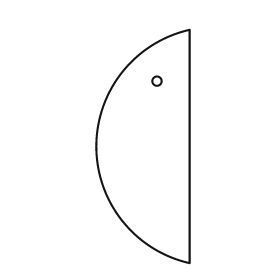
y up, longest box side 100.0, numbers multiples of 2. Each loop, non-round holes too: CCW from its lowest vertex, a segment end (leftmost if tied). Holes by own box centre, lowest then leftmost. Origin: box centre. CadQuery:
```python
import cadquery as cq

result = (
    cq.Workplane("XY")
    .moveTo(20.0, -50.0)
    .lineTo(20.0, 50.0)
    .threePointArc((-20.0, 0.0), (20.0, -50.0))
    .close()
    .moveTo(6.0, 28.0)
    .circle(2.0)
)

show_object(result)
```